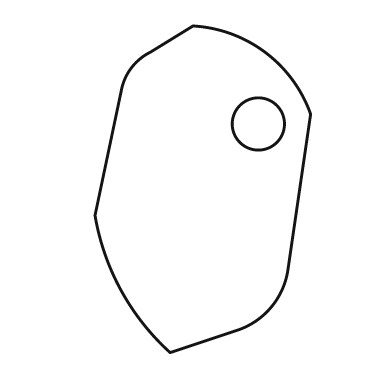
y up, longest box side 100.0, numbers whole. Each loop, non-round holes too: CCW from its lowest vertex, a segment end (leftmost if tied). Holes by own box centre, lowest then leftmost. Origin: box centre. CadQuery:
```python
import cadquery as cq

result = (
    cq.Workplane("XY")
    .moveTo(-10.0, -50.0)
    .lineTo(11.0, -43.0)
    .threePointArc((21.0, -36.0), (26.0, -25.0))
    .lineTo(33.0, 23.0)
    .threePointArc((19.0, 42.0), (-3.0, 50.0))
    .lineTo(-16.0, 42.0)
    .threePointArc((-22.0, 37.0), (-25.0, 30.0))
    .lineTo(-33.0, -8.0)
    .threePointArc((-25.0, -31.0), (-10.0, -50.0))
    .close()
    .moveTo(17.0, 20.0)
    .circle(8.0)
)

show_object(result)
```